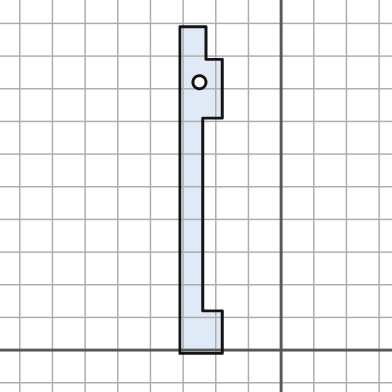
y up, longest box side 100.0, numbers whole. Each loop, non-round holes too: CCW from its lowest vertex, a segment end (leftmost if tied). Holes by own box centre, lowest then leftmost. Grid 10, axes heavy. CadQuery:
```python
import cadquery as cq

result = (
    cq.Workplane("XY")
    .moveTo(-31.0, -1.0)
    .lineTo(-18.0, -1.0)
    .lineTo(-18.0, 12.0)
    .lineTo(-24.0, 12.0)
    .lineTo(-24.0, 71.0)
    .lineTo(-18.0, 71.0)
    .lineTo(-18.0, 89.0)
    .lineTo(-23.0, 89.0)
    .lineTo(-23.0, 99.0)
    .lineTo(-31.0, 99.0)
    .close()
    .moveTo(-25.0, 82.0)
    .circle(2.0)
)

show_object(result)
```